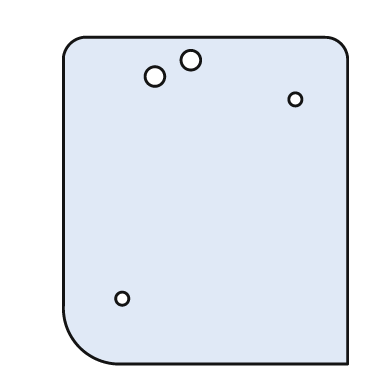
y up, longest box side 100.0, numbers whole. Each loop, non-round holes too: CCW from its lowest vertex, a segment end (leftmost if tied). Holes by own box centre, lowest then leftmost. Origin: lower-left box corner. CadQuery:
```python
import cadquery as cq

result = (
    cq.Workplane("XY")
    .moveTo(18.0, 0.0)
    .lineTo(87.0, 0.0)
    .lineTo(87.0, 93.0)
    .threePointArc((85.0, 98.0), (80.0, 100.0))
    .lineTo(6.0, 100.0)
    .threePointArc((2.0, 98.0), (0.0, 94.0))
    .lineTo(0.0, 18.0)
    .threePointArc((5.0, 5.0), (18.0, 0.0))
    .close()
    .moveTo(18.0, 20.0)
    .circle(2.0)
    .moveTo(71.0, 81.0)
    .circle(2.0)
    .moveTo(28.0, 88.0)
    .circle(3.0)
    .moveTo(39.0, 93.0)
    .circle(3.0)
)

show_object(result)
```